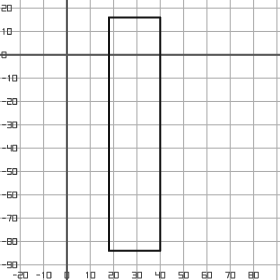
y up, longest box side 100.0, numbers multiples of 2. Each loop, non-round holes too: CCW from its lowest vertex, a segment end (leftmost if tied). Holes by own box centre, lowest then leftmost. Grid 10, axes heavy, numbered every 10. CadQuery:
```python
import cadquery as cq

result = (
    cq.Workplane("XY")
    .moveTo(18.0, -84.0)
    .lineTo(40.0, -84.0)
    .lineTo(40.0, 16.0)
    .lineTo(18.0, 16.0)
    .close()
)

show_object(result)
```